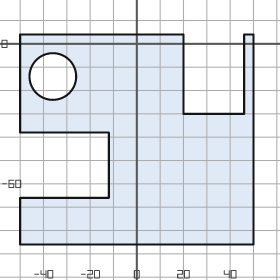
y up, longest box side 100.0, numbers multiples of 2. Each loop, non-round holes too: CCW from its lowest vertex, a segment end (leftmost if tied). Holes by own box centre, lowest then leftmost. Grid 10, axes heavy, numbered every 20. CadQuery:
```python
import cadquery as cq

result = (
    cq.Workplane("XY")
    .moveTo(-50.0, -86.0)
    .lineTo(50.0, -86.0)
    .lineTo(50.0, 4.0)
    .lineTo(46.0, 4.0)
    .lineTo(46.0, -30.0)
    .lineTo(20.0, -30.0)
    .lineTo(20.0, 4.0)
    .lineTo(-50.0, 4.0)
    .lineTo(-50.0, -38.0)
    .lineTo(-12.0, -38.0)
    .lineTo(-12.0, -66.0)
    .lineTo(-50.0, -66.0)
    .close()
    .moveTo(-36.0, -14.0)
    .circle(10.0)
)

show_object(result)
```